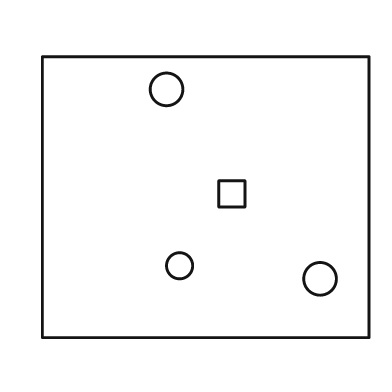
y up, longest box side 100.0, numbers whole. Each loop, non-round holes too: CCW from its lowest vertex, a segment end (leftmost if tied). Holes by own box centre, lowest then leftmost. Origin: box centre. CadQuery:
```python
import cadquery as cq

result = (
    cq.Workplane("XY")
    .moveTo(-50.0, -43.0)
    .lineTo(50.0, -43.0)
    .lineTo(50.0, 43.0)
    .lineTo(-50.0, 43.0)
    .close()
    .moveTo(35.0, -25.0)
    .circle(5.0)
    .moveTo(-8.0, -21.0)
    .circle(4.0)
    .moveTo(4.0, -3.0)
    .lineTo(12.0, -3.0)
    .lineTo(12.0, 5.0)
    .lineTo(4.0, 5.0)
    .close()
    .moveTo(-12.0, 33.0)
    .circle(5.0)
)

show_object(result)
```